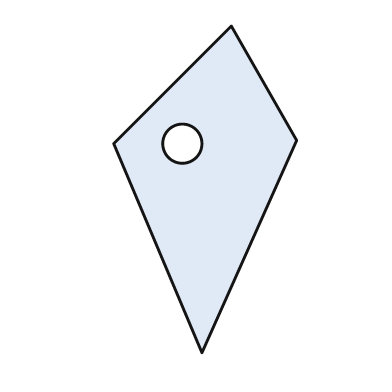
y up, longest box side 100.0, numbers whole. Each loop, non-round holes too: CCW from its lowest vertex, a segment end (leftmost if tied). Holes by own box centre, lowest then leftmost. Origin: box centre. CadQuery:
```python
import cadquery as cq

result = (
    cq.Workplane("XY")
    .moveTo(-1.0, -50.0)
    .lineTo(28.0, 15.0)
    .lineTo(8.0, 50.0)
    .lineTo(-28.0, 14.0)
    .close()
    .moveTo(-7.0, 14.0)
    .circle(6.0)
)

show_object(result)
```